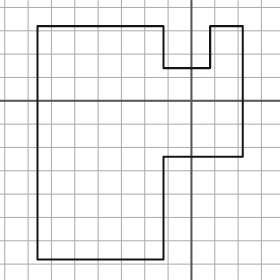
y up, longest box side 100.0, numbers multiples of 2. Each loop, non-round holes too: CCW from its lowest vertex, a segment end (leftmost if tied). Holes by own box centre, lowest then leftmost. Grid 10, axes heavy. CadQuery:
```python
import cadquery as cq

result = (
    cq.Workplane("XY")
    .moveTo(-66.0, -68.0)
    .lineTo(-12.0, -68.0)
    .lineTo(-12.0, -24.0)
    .lineTo(22.0, -24.0)
    .lineTo(22.0, 32.0)
    .lineTo(8.0, 32.0)
    .lineTo(8.0, 14.0)
    .lineTo(-12.0, 14.0)
    .lineTo(-12.0, 32.0)
    .lineTo(-66.0, 32.0)
    .close()
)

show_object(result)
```